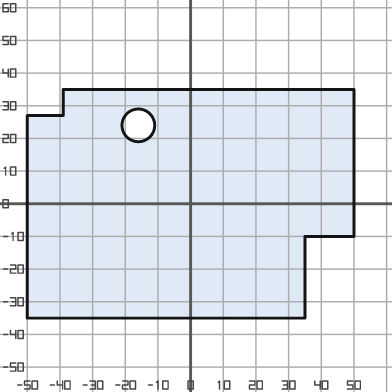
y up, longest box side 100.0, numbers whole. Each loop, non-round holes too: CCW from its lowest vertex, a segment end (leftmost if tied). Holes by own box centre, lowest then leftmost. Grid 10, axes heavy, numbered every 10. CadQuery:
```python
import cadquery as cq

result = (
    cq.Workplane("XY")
    .moveTo(-50.0, -35.0)
    .lineTo(35.0, -35.0)
    .lineTo(35.0, -10.0)
    .lineTo(50.0, -10.0)
    .lineTo(50.0, 35.0)
    .lineTo(-39.0, 35.0)
    .lineTo(-39.0, 27.0)
    .lineTo(-50.0, 27.0)
    .close()
    .moveTo(-16.0, 24.0)
    .circle(5.0)
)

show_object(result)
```